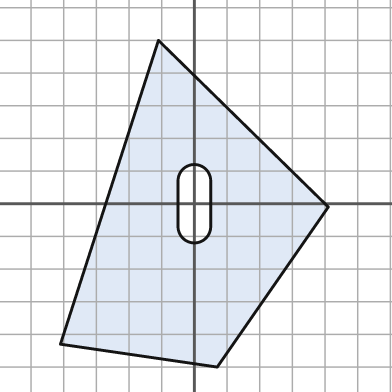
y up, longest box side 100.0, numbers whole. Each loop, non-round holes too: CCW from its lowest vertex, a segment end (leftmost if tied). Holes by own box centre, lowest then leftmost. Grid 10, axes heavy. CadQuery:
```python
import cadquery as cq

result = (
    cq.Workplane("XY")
    .moveTo(7.0, -50.0)
    .lineTo(41.0, -1.0)
    .lineTo(-11.0, 50.0)
    .lineTo(-41.0, -43.0)
    .close()
    .moveTo(-5.0, -7.0)
    .threePointArc((0.0, -12.0), (5.0, -7.0))
    .lineTo(5.0, 7.0)
    .threePointArc((0.0, 12.0), (-5.0, 7.0))
    .close()
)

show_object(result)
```